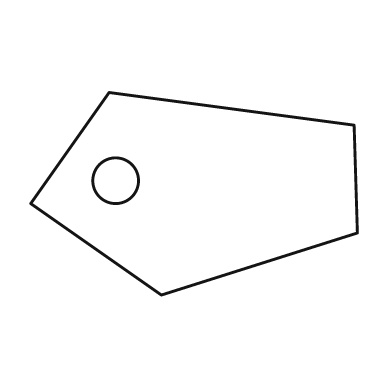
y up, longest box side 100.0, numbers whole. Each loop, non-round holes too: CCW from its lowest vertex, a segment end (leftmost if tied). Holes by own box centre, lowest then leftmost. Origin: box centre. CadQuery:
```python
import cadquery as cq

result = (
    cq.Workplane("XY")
    .moveTo(-10.0, -31.0)
    .lineTo(50.0, -12.0)
    .lineTo(49.0, 21.0)
    .lineTo(-26.0, 31.0)
    .lineTo(-50.0, -3.0)
    .close()
    .moveTo(-24.0, 4.0)
    .circle(7.0)
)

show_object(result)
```